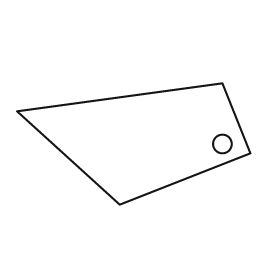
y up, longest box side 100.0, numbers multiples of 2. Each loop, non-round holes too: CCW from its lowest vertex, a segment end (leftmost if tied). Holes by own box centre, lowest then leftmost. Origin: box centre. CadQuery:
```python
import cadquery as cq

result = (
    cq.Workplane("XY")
    .moveTo(-6.0, -26.0)
    .lineTo(50.0, -4.0)
    .lineTo(38.0, 26.0)
    .lineTo(-50.0, 14.0)
    .close()
    .moveTo(38.0, 0.0)
    .circle(4.0)
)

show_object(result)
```